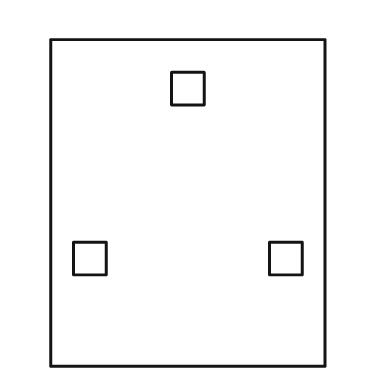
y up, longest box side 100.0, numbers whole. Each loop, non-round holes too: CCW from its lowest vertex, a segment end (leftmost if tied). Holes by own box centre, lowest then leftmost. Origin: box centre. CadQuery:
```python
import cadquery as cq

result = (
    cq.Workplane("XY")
    .moveTo(-42.0, -50.0)
    .lineTo(42.0, -50.0)
    .lineTo(42.0, 50.0)
    .lineTo(-42.0, 50.0)
    .close()
    .moveTo(-35.0, -22.0)
    .lineTo(-25.0, -22.0)
    .lineTo(-25.0, -12.0)
    .lineTo(-35.0, -12.0)
    .close()
    .moveTo(25.0, -22.0)
    .lineTo(35.0, -22.0)
    .lineTo(35.0, -12.0)
    .lineTo(25.0, -12.0)
    .close()
    .moveTo(-5.0, 30.0)
    .lineTo(5.0, 30.0)
    .lineTo(5.0, 40.0)
    .lineTo(-5.0, 40.0)
    .close()
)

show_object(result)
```